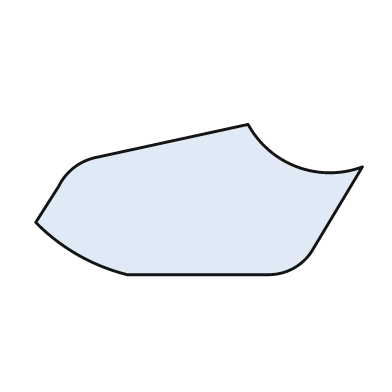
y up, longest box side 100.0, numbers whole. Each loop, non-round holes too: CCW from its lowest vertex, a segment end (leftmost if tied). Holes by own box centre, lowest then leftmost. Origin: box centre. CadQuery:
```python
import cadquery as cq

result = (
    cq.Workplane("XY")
    .moveTo(-22.0, -23.0)
    .lineTo(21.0, -23.0)
    .threePointArc((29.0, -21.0), (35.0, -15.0))
    .lineTo(50.0, 10.0)
    .threePointArc((30.0, 10.0), (15.0, 23.0))
    .lineTo(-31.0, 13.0)
    .threePointArc((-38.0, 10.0), (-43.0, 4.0))
    .lineTo(-50.0, -7.0)
    .threePointArc((-37.0, -17.0), (-22.0, -23.0))
    .close()
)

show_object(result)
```